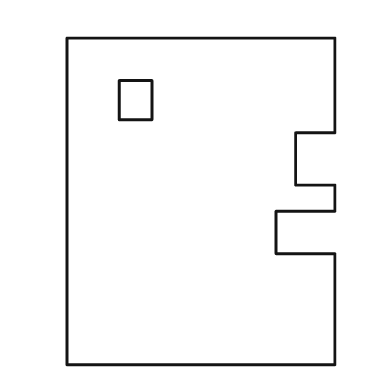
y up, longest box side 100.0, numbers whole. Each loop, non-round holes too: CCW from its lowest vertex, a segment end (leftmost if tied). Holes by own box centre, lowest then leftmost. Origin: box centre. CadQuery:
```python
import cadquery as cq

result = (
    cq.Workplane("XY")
    .moveTo(-41.0, -50.0)
    .lineTo(41.0, -50.0)
    .lineTo(41.0, -16.0)
    .lineTo(23.0, -16.0)
    .lineTo(23.0, -3.0)
    .lineTo(41.0, -3.0)
    .lineTo(41.0, 5.0)
    .lineTo(29.0, 5.0)
    .lineTo(29.0, 21.0)
    .lineTo(41.0, 21.0)
    .lineTo(41.0, 50.0)
    .lineTo(-41.0, 50.0)
    .close()
    .moveTo(-25.0, 25.0)
    .lineTo(-15.0, 25.0)
    .lineTo(-15.0, 37.0)
    .lineTo(-25.0, 37.0)
    .close()
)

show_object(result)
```